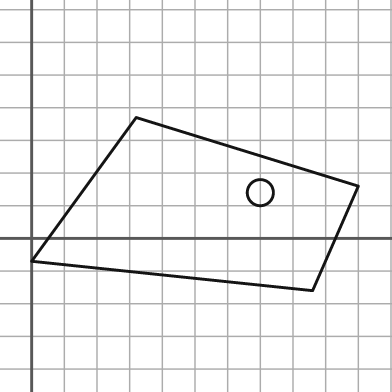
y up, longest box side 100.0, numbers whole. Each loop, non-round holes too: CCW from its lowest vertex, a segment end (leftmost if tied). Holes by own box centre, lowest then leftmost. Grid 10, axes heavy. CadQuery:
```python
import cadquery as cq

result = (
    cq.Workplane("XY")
    .moveTo(86.0, -16.0)
    .lineTo(100.0, 16.0)
    .lineTo(32.0, 37.0)
    .lineTo(0.0, -7.0)
    .close()
    .moveTo(70.0, 14.0)
    .circle(4.0)
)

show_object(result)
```